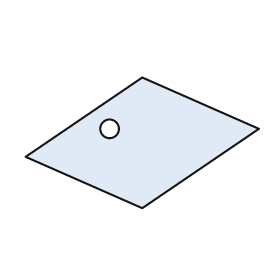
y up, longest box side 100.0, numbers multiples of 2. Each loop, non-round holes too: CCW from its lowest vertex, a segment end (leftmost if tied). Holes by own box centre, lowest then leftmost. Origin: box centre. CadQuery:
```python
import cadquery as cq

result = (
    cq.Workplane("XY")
    .moveTo(0.0, -28.0)
    .lineTo(50.0, 6.0)
    .lineTo(0.0, 28.0)
    .lineTo(-50.0, -6.0)
    .close()
    .moveTo(-14.0, 6.0)
    .circle(4.0)
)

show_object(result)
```